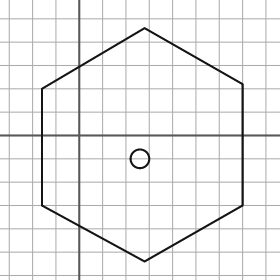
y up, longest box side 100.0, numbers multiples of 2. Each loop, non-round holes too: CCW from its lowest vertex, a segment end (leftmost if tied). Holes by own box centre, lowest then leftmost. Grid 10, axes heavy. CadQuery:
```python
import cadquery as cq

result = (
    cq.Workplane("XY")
    .moveTo(28.0, -54.0)
    .lineTo(70.0, -30.0)
    .lineTo(70.0, 22.0)
    .lineTo(28.0, 46.0)
    .lineTo(-16.0, 20.0)
    .lineTo(-16.0, -30.0)
    .close()
    .moveTo(26.0, -10.0)
    .circle(4.0)
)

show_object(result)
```